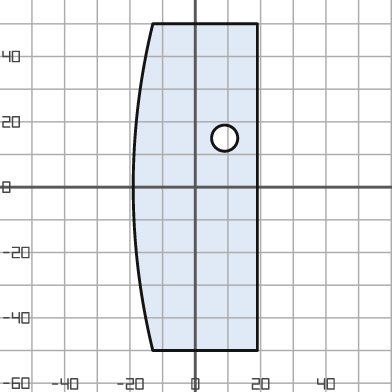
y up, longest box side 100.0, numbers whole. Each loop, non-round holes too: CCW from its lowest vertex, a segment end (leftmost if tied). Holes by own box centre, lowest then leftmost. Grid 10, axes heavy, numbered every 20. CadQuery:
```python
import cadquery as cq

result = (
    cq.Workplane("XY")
    .moveTo(-13.0, -50.0)
    .lineTo(19.0, -50.0)
    .lineTo(19.0, 50.0)
    .lineTo(-13.0, 50.0)
    .threePointArc((-19.0, 0.0), (-13.0, -50.0))
    .close()
    .moveTo(9.0, 15.0)
    .circle(4.0)
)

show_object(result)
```